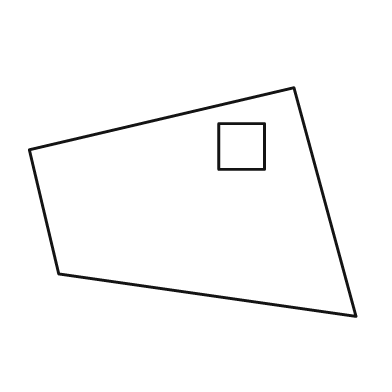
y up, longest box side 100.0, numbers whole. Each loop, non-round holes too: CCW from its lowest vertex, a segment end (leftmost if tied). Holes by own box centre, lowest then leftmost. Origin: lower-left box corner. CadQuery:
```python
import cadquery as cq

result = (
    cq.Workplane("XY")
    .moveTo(100.0, 0.0)
    .lineTo(81.0, 70.0)
    .lineTo(0.0, 51.0)
    .lineTo(9.0, 13.0)
    .close()
    .moveTo(58.0, 45.0)
    .lineTo(72.0, 45.0)
    .lineTo(72.0, 59.0)
    .lineTo(58.0, 59.0)
    .close()
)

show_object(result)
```